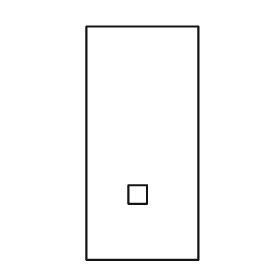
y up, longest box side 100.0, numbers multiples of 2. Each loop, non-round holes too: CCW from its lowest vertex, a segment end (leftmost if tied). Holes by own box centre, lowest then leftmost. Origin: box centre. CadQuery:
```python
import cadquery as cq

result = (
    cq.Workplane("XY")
    .moveTo(-24.0, -50.0)
    .lineTo(24.0, -50.0)
    .lineTo(24.0, 50.0)
    .lineTo(-24.0, 50.0)
    .close()
    .moveTo(-6.0, -26.0)
    .lineTo(2.0, -26.0)
    .lineTo(2.0, -18.0)
    .lineTo(-6.0, -18.0)
    .close()
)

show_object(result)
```